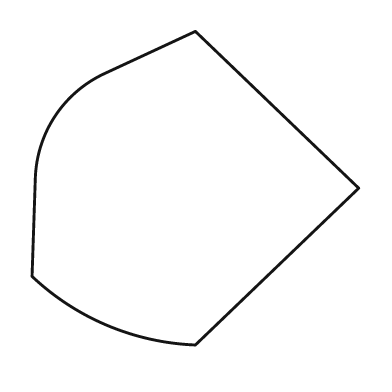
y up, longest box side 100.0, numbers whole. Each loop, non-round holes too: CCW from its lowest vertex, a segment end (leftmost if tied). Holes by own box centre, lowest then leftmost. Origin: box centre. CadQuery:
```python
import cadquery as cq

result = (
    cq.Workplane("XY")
    .moveTo(0.0, -48.0)
    .lineTo(50.0, 0.0)
    .lineTo(0.0, 48.0)
    .lineTo(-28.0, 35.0)
    .threePointArc((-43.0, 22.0), (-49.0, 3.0))
    .lineTo(-50.0, -27.0)
    .threePointArc((-27.0, -42.0), (0.0, -48.0))
    .close()
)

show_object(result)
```